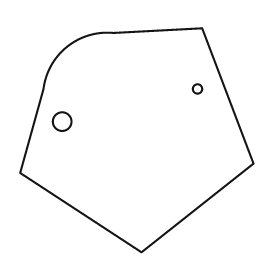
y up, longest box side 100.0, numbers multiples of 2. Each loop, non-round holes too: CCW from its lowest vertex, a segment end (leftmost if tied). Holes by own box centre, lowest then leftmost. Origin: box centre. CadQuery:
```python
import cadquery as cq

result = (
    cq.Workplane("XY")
    .moveTo(2.0, -48.0)
    .lineTo(50.0, -10.0)
    .lineTo(28.0, 48.0)
    .lineTo(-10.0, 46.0)
    .threePointArc((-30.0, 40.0), (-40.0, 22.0))
    .lineTo(-50.0, -14.0)
    .close()
    .moveTo(-32.0, 8.0)
    .circle(4.0)
    .moveTo(26.0, 22.0)
    .circle(2.0)
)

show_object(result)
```